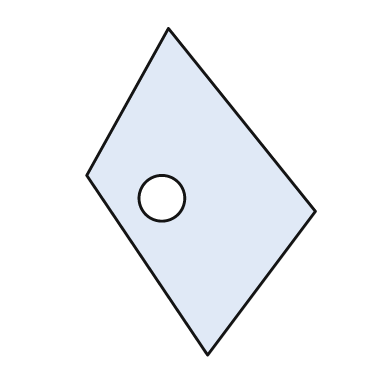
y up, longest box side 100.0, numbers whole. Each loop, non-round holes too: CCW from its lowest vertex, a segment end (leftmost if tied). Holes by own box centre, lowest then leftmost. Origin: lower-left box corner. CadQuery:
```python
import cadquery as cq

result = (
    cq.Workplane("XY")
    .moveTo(37.0, 0.0)
    .lineTo(70.0, 44.0)
    .lineTo(25.0, 100.0)
    .lineTo(0.0, 55.0)
    .close()
    .moveTo(23.0, 48.0)
    .circle(7.0)
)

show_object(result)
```